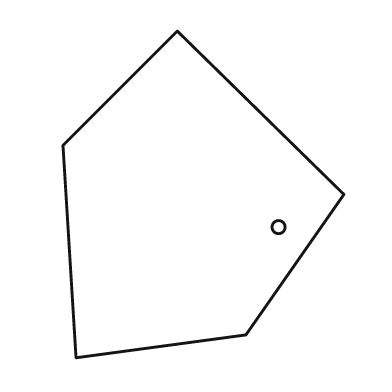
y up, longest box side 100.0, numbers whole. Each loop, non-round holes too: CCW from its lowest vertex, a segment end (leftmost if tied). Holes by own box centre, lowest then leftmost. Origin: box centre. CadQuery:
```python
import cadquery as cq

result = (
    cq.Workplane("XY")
    .moveTo(-39.0, -50.0)
    .lineTo(13.0, -43.0)
    .lineTo(43.0, 0.0)
    .lineTo(-8.0, 50.0)
    .lineTo(-43.0, 15.0)
    .close()
    .moveTo(23.0, -10.0)
    .circle(2.0)
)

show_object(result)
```